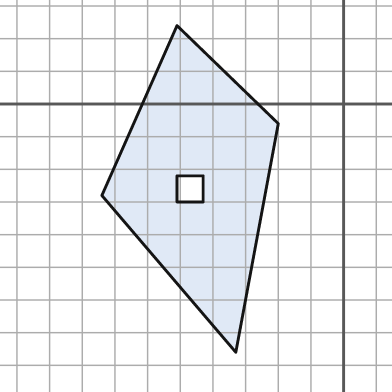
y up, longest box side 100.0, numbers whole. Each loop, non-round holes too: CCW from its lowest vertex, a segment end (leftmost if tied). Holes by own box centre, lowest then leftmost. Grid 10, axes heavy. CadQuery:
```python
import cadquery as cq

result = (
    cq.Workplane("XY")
    .moveTo(-33.0, -76.0)
    .lineTo(-20.0, -6.0)
    .lineTo(-51.0, 24.0)
    .lineTo(-74.0, -28.0)
    .close()
    .moveTo(-51.0, -30.0)
    .lineTo(-43.0, -30.0)
    .lineTo(-43.0, -22.0)
    .lineTo(-51.0, -22.0)
    .close()
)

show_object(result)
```